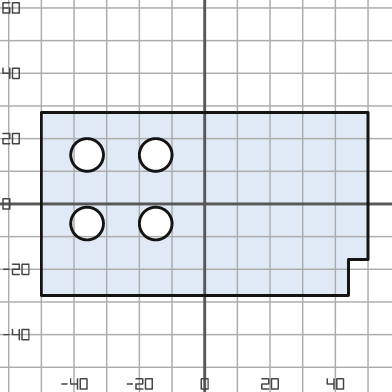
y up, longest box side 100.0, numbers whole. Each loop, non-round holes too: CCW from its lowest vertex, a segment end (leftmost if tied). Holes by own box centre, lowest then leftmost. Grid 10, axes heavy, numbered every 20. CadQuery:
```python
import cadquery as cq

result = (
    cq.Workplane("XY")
    .moveTo(-50.0, -28.0)
    .lineTo(44.0, -28.0)
    .lineTo(44.0, -17.0)
    .lineTo(50.0, -17.0)
    .lineTo(50.0, 28.0)
    .lineTo(-50.0, 28.0)
    .close()
    .moveTo(-36.0, -6.0)
    .circle(5.0)
    .moveTo(-15.0, -6.0)
    .circle(5.0)
    .moveTo(-36.0, 15.0)
    .circle(5.0)
    .moveTo(-15.0, 15.0)
    .circle(5.0)
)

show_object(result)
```